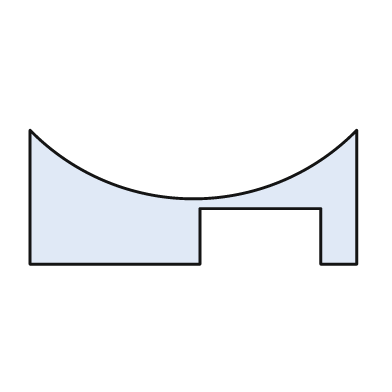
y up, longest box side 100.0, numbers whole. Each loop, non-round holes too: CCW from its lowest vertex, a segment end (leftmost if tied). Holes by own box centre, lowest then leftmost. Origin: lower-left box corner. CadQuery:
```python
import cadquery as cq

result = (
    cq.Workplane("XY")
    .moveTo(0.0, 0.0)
    .lineTo(52.0, 0.0)
    .lineTo(52.0, 17.0)
    .lineTo(89.0, 17.0)
    .lineTo(89.0, 0.0)
    .lineTo(100.0, 0.0)
    .lineTo(100.0, 41.0)
    .threePointArc((50.0, 20.0), (0.0, 41.0))
    .close()
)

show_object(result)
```